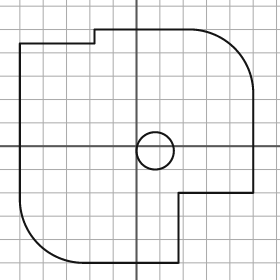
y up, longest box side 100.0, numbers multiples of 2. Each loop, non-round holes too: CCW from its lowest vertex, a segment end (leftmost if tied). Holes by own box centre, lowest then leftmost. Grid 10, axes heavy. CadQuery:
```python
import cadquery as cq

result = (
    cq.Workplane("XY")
    .moveTo(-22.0, -50.0)
    .lineTo(18.0, -50.0)
    .lineTo(18.0, -20.0)
    .lineTo(50.0, -20.0)
    .lineTo(50.0, 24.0)
    .threePointArc((42.0, 42.0), (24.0, 50.0))
    .lineTo(-18.0, 50.0)
    .lineTo(-18.0, 44.0)
    .lineTo(-50.0, 44.0)
    .lineTo(-50.0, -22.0)
    .threePointArc((-42.0, -42.0), (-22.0, -50.0))
    .close()
    .moveTo(8.0, -2.0)
    .circle(8.0)
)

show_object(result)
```